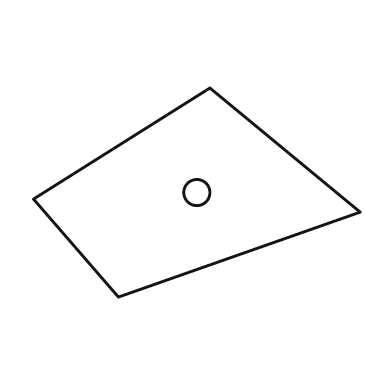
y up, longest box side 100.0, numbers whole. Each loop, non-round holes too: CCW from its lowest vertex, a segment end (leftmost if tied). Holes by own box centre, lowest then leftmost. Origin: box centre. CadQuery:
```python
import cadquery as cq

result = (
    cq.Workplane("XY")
    .moveTo(-24.0, -32.0)
    .lineTo(50.0, -6.0)
    .lineTo(4.0, 32.0)
    .lineTo(-50.0, -2.0)
    .close()
    .moveTo(0.0, 0.0)
    .circle(4.0)
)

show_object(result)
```